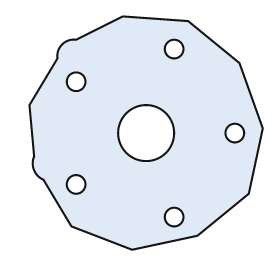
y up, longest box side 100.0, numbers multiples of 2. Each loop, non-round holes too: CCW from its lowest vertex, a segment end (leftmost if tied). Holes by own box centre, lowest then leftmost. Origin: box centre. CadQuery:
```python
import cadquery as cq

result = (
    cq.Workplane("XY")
    .moveTo(-6.0, -50.0)
    .lineTo(22.0, -44.0)
    .lineTo(44.0, -26.0)
    .lineTo(50.0, 2.0)
    .lineTo(40.0, 30.0)
    .lineTo(18.0, 48.0)
    .lineTo(-10.0, 50.0)
    .lineTo(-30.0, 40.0)
    .threePointArc((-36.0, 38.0), (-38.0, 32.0))
    .lineTo(-50.0, 12.0)
    .lineTo(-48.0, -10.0)
    .threePointArc((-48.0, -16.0), (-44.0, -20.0))
    .lineTo(-32.0, -40.0)
    .close()
    .moveTo(12.0, -36.0)
    .circle(4.0)
    .moveTo(-30.0, -22.0)
    .circle(4.0)
    .moveTo(0.0, 0.0)
    .circle(12.0)
    .moveTo(38.0, 0.0)
    .circle(4.0)
    .moveTo(-30.0, 22.0)
    .circle(4.0)
    .moveTo(12.0, 36.0)
    .circle(4.0)
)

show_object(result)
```